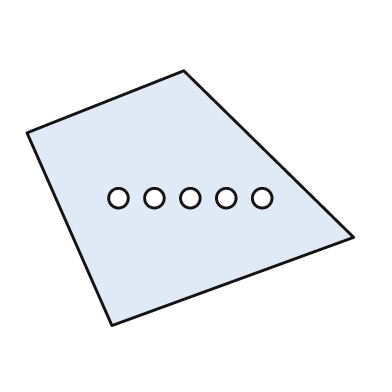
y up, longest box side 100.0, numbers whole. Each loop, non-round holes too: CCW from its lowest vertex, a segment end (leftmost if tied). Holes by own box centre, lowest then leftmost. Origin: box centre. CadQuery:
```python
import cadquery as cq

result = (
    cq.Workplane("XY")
    .moveTo(-24.0, -39.0)
    .lineTo(50.0, -12.0)
    .lineTo(-2.0, 39.0)
    .lineTo(-50.0, 20.0)
    .close()
    .moveTo(-22.0, 0.0)
    .circle(3.0)
    .moveTo(-11.0, 0.0)
    .circle(3.0)
    .moveTo(0.0, 0.0)
    .circle(3.0)
    .moveTo(11.0, 0.0)
    .circle(3.0)
    .moveTo(22.0, 0.0)
    .circle(3.0)
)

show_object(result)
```